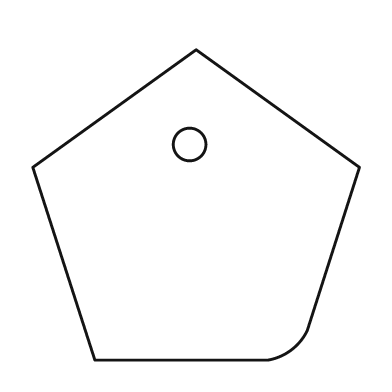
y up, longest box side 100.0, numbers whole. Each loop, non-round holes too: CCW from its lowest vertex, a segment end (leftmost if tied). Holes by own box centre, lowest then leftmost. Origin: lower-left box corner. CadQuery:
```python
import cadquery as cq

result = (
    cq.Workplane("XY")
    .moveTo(19.0, 0.0)
    .lineTo(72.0, 0.0)
    .threePointArc((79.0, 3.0), (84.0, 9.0))
    .lineTo(100.0, 59.0)
    .lineTo(50.0, 95.0)
    .lineTo(0.0, 59.0)
    .close()
    .moveTo(48.0, 66.0)
    .circle(5.0)
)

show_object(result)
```